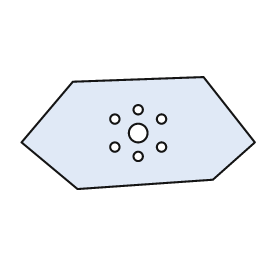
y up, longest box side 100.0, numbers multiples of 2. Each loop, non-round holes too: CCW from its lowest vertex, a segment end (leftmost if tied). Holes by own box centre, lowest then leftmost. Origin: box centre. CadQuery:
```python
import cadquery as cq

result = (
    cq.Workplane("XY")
    .moveTo(-26.0, -24.0)
    .lineTo(32.0, -20.0)
    .lineTo(50.0, -4.0)
    .lineTo(28.0, 24.0)
    .lineTo(-28.0, 22.0)
    .lineTo(-50.0, -4.0)
    .close()
    .moveTo(0.0, -10.0)
    .circle(2.0)
    .moveTo(-10.0, -6.0)
    .circle(2.0)
    .moveTo(10.0, -6.0)
    .circle(2.0)
    .moveTo(0.0, 0.0)
    .circle(4.0)
    .moveTo(-10.0, 6.0)
    .circle(2.0)
    .moveTo(10.0, 6.0)
    .circle(2.0)
    .moveTo(0.0, 10.0)
    .circle(2.0)
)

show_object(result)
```